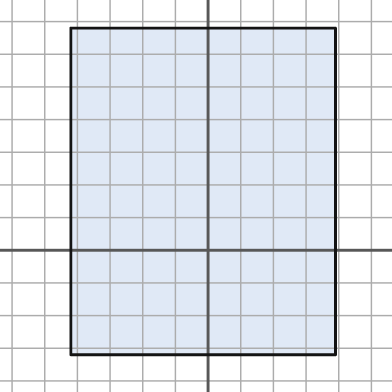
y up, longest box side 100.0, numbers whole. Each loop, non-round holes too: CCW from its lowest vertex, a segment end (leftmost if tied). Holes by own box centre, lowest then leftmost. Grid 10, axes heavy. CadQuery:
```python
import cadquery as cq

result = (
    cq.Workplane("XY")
    .moveTo(-42.0, -32.0)
    .lineTo(39.0, -32.0)
    .lineTo(39.0, 68.0)
    .lineTo(-42.0, 68.0)
    .close()
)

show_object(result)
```